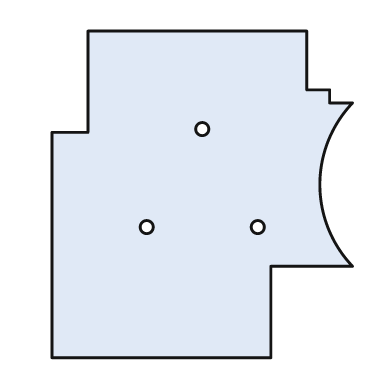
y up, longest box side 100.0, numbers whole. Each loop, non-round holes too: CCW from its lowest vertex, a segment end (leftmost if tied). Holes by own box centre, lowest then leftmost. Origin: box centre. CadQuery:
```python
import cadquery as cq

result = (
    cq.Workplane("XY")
    .moveTo(-46.0, -50.0)
    .lineTo(21.0, -50.0)
    .lineTo(21.0, -22.0)
    .lineTo(46.0, -22.0)
    .threePointArc((36.0, 3.0), (46.0, 28.0))
    .lineTo(39.0, 28.0)
    .lineTo(39.0, 32.0)
    .lineTo(32.0, 32.0)
    .lineTo(32.0, 50.0)
    .lineTo(-35.0, 50.0)
    .lineTo(-35.0, 19.0)
    .lineTo(-46.0, 19.0)
    .close()
    .moveTo(-17.0, -10.0)
    .circle(2.0)
    .moveTo(17.0, -10.0)
    .circle(2.0)
    .moveTo(0.0, 20.0)
    .circle(2.0)
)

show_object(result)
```